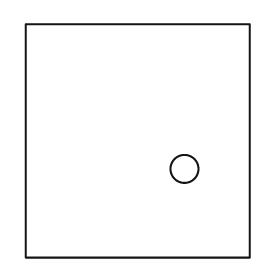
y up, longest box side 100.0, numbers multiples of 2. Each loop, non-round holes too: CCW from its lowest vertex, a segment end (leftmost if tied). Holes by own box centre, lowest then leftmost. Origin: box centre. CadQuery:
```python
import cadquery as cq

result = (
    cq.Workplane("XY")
    .moveTo(-48.0, -50.0)
    .lineTo(48.0, -50.0)
    .lineTo(48.0, 50.0)
    .lineTo(-48.0, 50.0)
    .close()
    .moveTo(20.0, -12.0)
    .circle(6.0)
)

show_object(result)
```